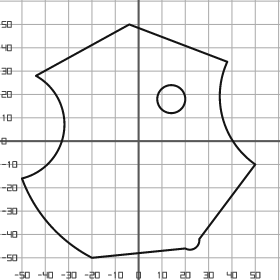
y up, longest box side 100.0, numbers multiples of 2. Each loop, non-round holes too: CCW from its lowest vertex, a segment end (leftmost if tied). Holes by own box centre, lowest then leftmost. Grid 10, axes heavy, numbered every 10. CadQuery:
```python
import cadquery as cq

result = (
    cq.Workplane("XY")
    .moveTo(-20.0, -50.0)
    .lineTo(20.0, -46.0)
    .threePointArc((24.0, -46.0), (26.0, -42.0))
    .lineTo(50.0, -10.0)
    .threePointArc((36.0, 10.0), (38.0, 34.0))
    .lineTo(-4.0, 50.0)
    .lineTo(-44.0, 28.0)
    .threePointArc((-32.0, 4.0), (-50.0, -16.0))
    .threePointArc((-38.0, -36.0), (-20.0, -50.0))
    .close()
    .moveTo(14.0, 18.0)
    .circle(6.0)
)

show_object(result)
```